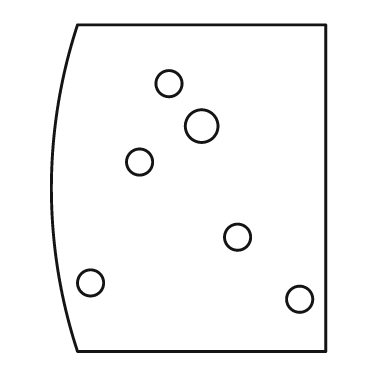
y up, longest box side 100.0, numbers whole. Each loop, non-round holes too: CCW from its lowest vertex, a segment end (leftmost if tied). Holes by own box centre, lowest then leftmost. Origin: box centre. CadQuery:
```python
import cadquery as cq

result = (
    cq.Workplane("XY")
    .moveTo(-34.0, -50.0)
    .lineTo(42.0, -50.0)
    .lineTo(42.0, 50.0)
    .lineTo(-34.0, 50.0)
    .threePointArc((-42.0, 0.0), (-34.0, -50.0))
    .close()
    .moveTo(34.0, -34.0)
    .circle(4.0)
    .moveTo(-30.0, -29.0)
    .circle(4.0)
    .moveTo(15.0, -15.0)
    .circle(4.0)
    .moveTo(-15.0, 8.0)
    .circle(4.0)
    .moveTo(4.0, 19.0)
    .circle(5.0)
    .moveTo(-6.0, 32.0)
    .circle(4.0)
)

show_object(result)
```